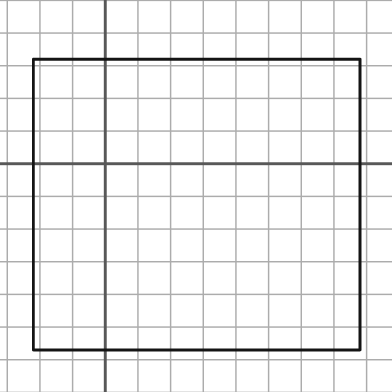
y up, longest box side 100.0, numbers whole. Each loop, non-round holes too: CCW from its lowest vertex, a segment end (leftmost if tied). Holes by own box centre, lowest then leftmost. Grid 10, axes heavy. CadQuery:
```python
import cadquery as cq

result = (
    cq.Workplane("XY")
    .moveTo(-22.0, -57.0)
    .lineTo(78.0, -57.0)
    .lineTo(78.0, 32.0)
    .lineTo(-22.0, 32.0)
    .close()
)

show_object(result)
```